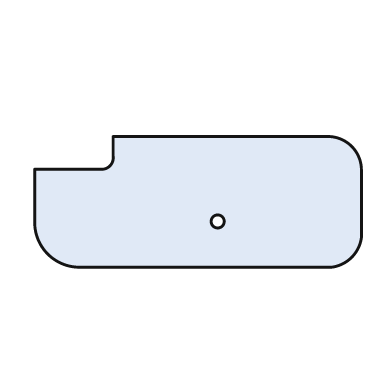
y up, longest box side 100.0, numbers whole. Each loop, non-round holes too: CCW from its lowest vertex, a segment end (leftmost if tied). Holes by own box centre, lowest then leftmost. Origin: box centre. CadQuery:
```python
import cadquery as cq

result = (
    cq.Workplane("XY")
    .moveTo(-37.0, -20.0)
    .lineTo(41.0, -20.0)
    .threePointArc((47.0, -17.0), (50.0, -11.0))
    .lineTo(50.0, 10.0)
    .threePointArc((47.0, 17.0), (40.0, 20.0))
    .lineTo(-26.0, 20.0)
    .lineTo(-26.0, 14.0)
    .threePointArc((-27.0, 11.0), (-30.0, 10.0))
    .lineTo(-50.0, 10.0)
    .lineTo(-50.0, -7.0)
    .threePointArc((-46.0, -16.0), (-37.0, -20.0))
    .close()
    .moveTo(6.0, -6.0)
    .circle(2.0)
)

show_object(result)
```